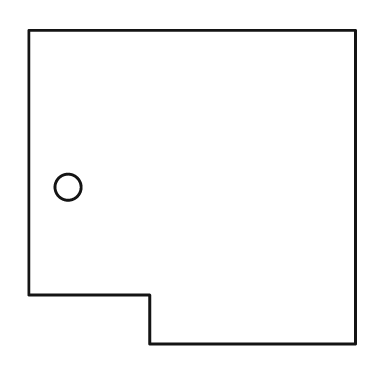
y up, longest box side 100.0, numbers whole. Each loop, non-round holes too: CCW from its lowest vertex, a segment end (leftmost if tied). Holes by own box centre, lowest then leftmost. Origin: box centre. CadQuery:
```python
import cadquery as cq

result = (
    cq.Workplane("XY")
    .moveTo(-13.0, -48.0)
    .lineTo(50.0, -48.0)
    .lineTo(50.0, 48.0)
    .lineTo(-50.0, 48.0)
    .lineTo(-50.0, -33.0)
    .lineTo(-13.0, -33.0)
    .close()
    .moveTo(-38.0, 0.0)
    .circle(4.0)
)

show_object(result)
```